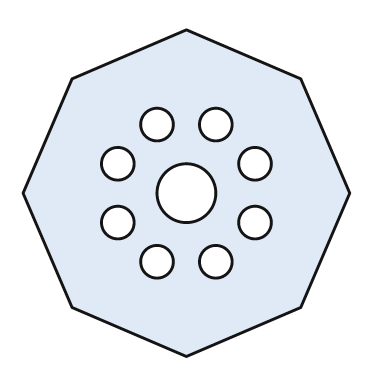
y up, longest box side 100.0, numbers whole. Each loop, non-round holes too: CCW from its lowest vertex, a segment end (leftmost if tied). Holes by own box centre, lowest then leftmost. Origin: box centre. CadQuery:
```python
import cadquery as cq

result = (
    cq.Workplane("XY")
    .moveTo(0.0, -50.0)
    .lineTo(35.0, -35.0)
    .lineTo(50.0, 0.0)
    .lineTo(35.0, 35.0)
    .lineTo(0.0, 50.0)
    .lineTo(-35.0, 35.0)
    .lineTo(-50.0, 0.0)
    .lineTo(-35.0, -35.0)
    .close()
    .moveTo(-9.0, -21.0)
    .circle(5.0)
    .moveTo(9.0, -21.0)
    .circle(5.0)
    .moveTo(-21.0, -9.0)
    .circle(5.0)
    .moveTo(21.0, -9.0)
    .circle(5.0)
    .moveTo(0.0, 0.0)
    .circle(9.0)
    .moveTo(-21.0, 9.0)
    .circle(5.0)
    .moveTo(21.0, 9.0)
    .circle(5.0)
    .moveTo(-9.0, 21.0)
    .circle(5.0)
    .moveTo(9.0, 21.0)
    .circle(5.0)
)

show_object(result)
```